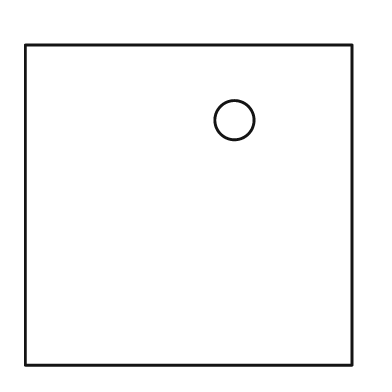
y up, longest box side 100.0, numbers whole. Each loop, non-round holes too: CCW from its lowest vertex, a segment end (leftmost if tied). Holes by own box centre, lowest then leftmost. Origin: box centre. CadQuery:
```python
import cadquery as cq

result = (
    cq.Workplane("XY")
    .moveTo(-50.0, -49.0)
    .lineTo(50.0, -49.0)
    .lineTo(50.0, 49.0)
    .lineTo(-50.0, 49.0)
    .close()
    .moveTo(14.0, 26.0)
    .circle(6.0)
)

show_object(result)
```